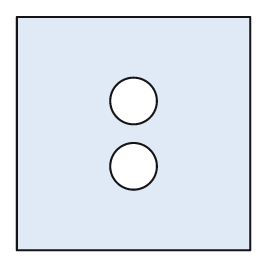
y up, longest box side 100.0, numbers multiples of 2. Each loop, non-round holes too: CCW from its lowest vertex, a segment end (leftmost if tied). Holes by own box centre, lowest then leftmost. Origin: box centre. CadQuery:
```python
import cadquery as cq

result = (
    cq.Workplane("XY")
    .moveTo(-50.0, -50.0)
    .lineTo(50.0, -50.0)
    .lineTo(50.0, 50.0)
    .lineTo(-50.0, 50.0)
    .close()
    .moveTo(0.0, -14.0)
    .circle(10.0)
    .moveTo(0.0, 14.0)
    .circle(10.0)
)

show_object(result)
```